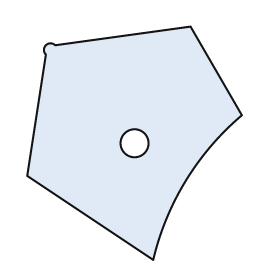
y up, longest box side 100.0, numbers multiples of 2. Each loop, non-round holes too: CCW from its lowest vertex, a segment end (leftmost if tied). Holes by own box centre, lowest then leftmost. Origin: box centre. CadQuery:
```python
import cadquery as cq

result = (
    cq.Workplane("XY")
    .moveTo(8.0, -50.0)
    .threePointArc((22.0, -16.0), (46.0, 12.0))
    .lineTo(24.0, 50.0)
    .lineTo(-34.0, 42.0)
    .threePointArc((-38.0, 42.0), (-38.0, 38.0))
    .lineTo(-46.0, -14.0)
    .close()
    .moveTo(0.0, 0.0)
    .circle(6.0)
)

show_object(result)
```